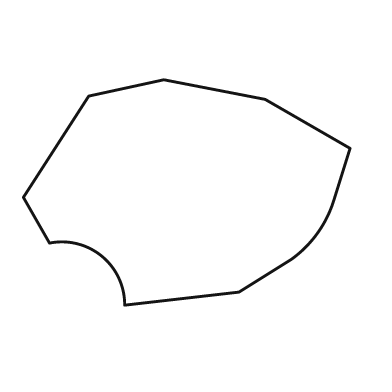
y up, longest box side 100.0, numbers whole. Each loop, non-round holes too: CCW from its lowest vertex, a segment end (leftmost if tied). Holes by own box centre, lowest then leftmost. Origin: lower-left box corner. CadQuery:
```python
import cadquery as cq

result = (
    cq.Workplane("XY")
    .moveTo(31.0, 0.0)
    .lineTo(66.0, 4.0)
    .lineTo(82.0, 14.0)
    .threePointArc((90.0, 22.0), (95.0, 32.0))
    .lineTo(100.0, 48.0)
    .lineTo(74.0, 63.0)
    .lineTo(43.0, 69.0)
    .lineTo(20.0, 64.0)
    .lineTo(0.0, 33.0)
    .lineTo(8.0, 19.0)
    .threePointArc((24.0, 15.0), (31.0, 0.0))
    .close()
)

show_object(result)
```